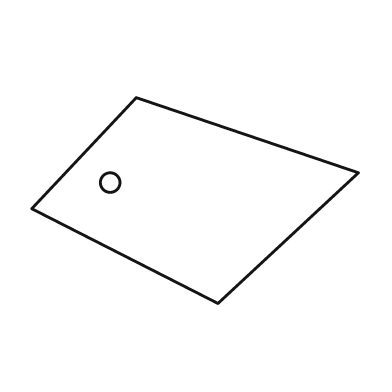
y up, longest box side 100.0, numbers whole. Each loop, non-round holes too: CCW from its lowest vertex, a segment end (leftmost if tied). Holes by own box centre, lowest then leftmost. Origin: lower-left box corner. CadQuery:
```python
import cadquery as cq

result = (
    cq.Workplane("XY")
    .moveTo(57.0, 0.0)
    .lineTo(100.0, 40.0)
    .lineTo(32.0, 63.0)
    .lineTo(0.0, 29.0)
    .close()
    .moveTo(24.0, 37.0)
    .circle(3.0)
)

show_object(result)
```